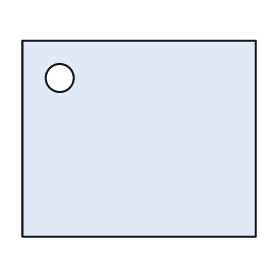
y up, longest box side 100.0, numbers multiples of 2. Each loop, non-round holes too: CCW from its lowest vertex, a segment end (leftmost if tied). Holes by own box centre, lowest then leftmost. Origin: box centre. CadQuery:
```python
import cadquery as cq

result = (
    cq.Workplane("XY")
    .moveTo(-50.0, -42.0)
    .lineTo(50.0, -42.0)
    .lineTo(50.0, 42.0)
    .lineTo(-50.0, 42.0)
    .close()
    .moveTo(-34.0, 26.0)
    .circle(6.0)
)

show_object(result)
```